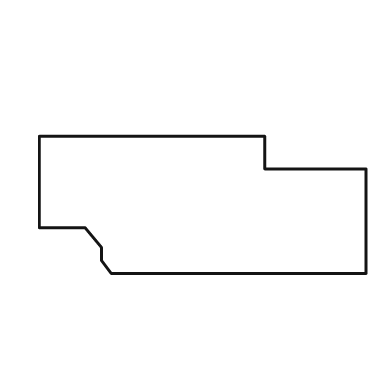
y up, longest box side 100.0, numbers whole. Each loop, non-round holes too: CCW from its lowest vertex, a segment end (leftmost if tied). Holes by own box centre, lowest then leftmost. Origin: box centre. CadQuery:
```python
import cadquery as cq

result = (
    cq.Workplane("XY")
    .moveTo(-28.0, -21.0)
    .lineTo(50.0, -21.0)
    .lineTo(50.0, 11.0)
    .lineTo(19.0, 11.0)
    .lineTo(19.0, 21.0)
    .lineTo(-50.0, 21.0)
    .lineTo(-50.0, -7.0)
    .lineTo(-36.0, -7.0)
    .lineTo(-31.0, -13.0)
    .lineTo(-31.0, -17.0)
    .close()
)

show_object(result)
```